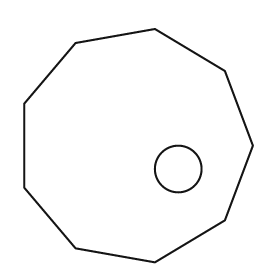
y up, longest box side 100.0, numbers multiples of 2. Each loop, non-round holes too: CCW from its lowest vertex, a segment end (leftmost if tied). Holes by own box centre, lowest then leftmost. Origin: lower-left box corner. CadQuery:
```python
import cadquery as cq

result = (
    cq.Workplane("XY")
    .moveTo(56.0, 0.0)
    .lineTo(86.0, 18.0)
    .lineTo(98.0, 50.0)
    .lineTo(86.0, 82.0)
    .lineTo(56.0, 100.0)
    .lineTo(22.0, 94.0)
    .lineTo(0.0, 68.0)
    .lineTo(0.0, 32.0)
    .lineTo(22.0, 6.0)
    .close()
    .moveTo(66.0, 40.0)
    .circle(10.0)
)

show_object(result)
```